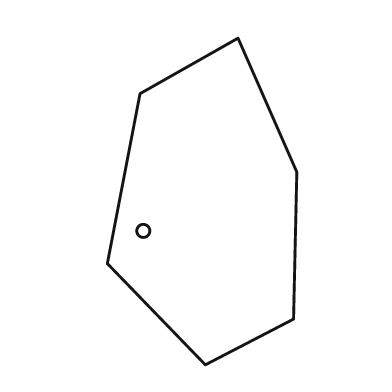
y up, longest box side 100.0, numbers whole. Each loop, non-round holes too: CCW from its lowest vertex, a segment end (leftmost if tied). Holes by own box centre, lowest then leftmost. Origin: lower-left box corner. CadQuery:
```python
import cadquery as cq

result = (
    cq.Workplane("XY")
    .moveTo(30.0, 0.0)
    .lineTo(57.0, 14.0)
    .lineTo(58.0, 59.0)
    .lineTo(40.0, 100.0)
    .lineTo(10.0, 83.0)
    .lineTo(0.0, 31.0)
    .close()
    .moveTo(11.0, 41.0)
    .circle(2.0)
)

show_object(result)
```